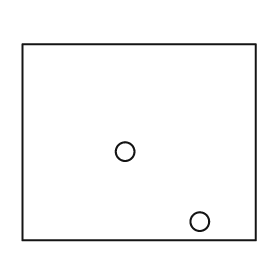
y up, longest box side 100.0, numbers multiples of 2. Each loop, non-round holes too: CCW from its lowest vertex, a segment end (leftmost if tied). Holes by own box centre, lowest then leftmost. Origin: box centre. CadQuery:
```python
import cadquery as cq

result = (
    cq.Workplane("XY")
    .moveTo(-50.0, -42.0)
    .lineTo(50.0, -42.0)
    .lineTo(50.0, 42.0)
    .lineTo(-50.0, 42.0)
    .close()
    .moveTo(26.0, -34.0)
    .circle(4.0)
    .moveTo(-6.0, -4.0)
    .circle(4.0)
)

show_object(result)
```